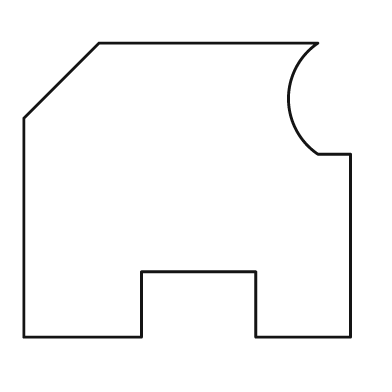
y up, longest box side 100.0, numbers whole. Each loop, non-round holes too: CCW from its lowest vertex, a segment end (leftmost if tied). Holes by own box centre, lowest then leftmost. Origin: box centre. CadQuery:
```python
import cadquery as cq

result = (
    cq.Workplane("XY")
    .moveTo(-50.0, -45.0)
    .lineTo(-14.0, -45.0)
    .lineTo(-14.0, -25.0)
    .lineTo(21.0, -25.0)
    .lineTo(21.0, -45.0)
    .lineTo(50.0, -45.0)
    .lineTo(50.0, 11.0)
    .lineTo(40.0, 11.0)
    .threePointArc((31.0, 28.0), (40.0, 45.0))
    .lineTo(-27.0, 45.0)
    .lineTo(-50.0, 22.0)
    .close()
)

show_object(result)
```